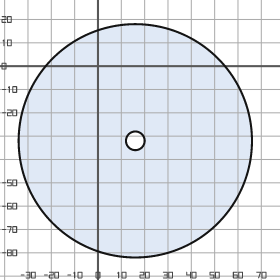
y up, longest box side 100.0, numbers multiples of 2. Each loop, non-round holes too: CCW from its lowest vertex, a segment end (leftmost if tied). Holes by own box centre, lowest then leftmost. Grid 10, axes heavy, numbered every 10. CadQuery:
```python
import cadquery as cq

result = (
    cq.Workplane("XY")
    .moveTo(16.0, -32.0)
    .circle(50.0)
    .moveTo(16.0, -32.0)
    .circle(4.0)
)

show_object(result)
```